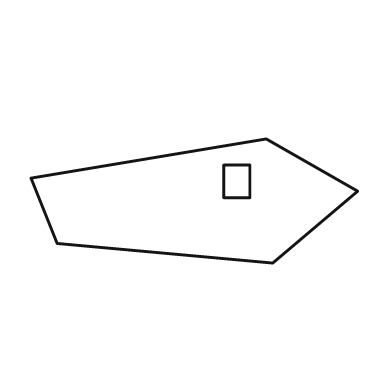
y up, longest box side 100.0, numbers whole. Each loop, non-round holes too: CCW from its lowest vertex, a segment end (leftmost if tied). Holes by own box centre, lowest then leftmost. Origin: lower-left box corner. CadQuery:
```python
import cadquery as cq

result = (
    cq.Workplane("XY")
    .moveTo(74.0, 0.0)
    .lineTo(100.0, 22.0)
    .lineTo(72.0, 38.0)
    .lineTo(0.0, 26.0)
    .lineTo(8.0, 6.0)
    .close()
    .moveTo(59.0, 20.0)
    .lineTo(67.0, 20.0)
    .lineTo(67.0, 30.0)
    .lineTo(59.0, 30.0)
    .close()
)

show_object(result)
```